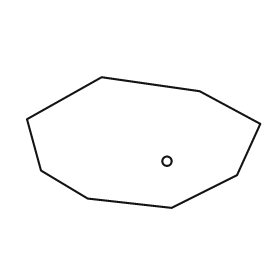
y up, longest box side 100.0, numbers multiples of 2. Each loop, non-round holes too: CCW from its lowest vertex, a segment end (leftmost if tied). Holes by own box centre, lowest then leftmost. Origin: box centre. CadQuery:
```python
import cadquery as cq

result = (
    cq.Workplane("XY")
    .moveTo(12.0, -28.0)
    .lineTo(40.0, -14.0)
    .lineTo(50.0, 8.0)
    .lineTo(24.0, 22.0)
    .lineTo(-18.0, 28.0)
    .lineTo(-50.0, 10.0)
    .lineTo(-44.0, -12.0)
    .lineTo(-24.0, -24.0)
    .close()
    .moveTo(10.0, -8.0)
    .circle(2.0)
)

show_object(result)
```